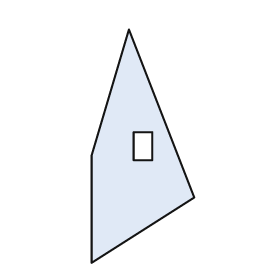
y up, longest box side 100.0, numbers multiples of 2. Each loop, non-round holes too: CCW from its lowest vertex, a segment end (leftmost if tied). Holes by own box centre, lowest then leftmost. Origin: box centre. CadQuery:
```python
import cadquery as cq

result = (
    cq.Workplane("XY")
    .moveTo(-22.0, -50.0)
    .lineTo(22.0, -22.0)
    .lineTo(-6.0, 50.0)
    .lineTo(-22.0, -4.0)
    .close()
    .moveTo(-4.0, -6.0)
    .lineTo(4.0, -6.0)
    .lineTo(4.0, 6.0)
    .lineTo(-4.0, 6.0)
    .close()
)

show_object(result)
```